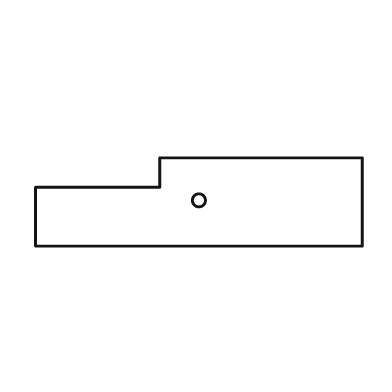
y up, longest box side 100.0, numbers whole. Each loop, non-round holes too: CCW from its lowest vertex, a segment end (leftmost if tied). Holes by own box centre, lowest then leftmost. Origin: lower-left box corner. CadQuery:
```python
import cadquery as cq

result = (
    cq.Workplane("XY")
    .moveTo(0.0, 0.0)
    .lineTo(100.0, 0.0)
    .lineTo(100.0, 27.0)
    .lineTo(38.0, 27.0)
    .lineTo(38.0, 18.0)
    .lineTo(0.0, 18.0)
    .close()
    .moveTo(50.0, 14.0)
    .circle(2.0)
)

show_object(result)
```